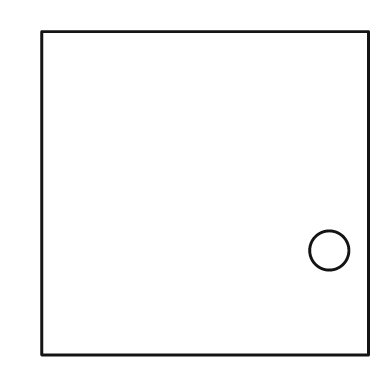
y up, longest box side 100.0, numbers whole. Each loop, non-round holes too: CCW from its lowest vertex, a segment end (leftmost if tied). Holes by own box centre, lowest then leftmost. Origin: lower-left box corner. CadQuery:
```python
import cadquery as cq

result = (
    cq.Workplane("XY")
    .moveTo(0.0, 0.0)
    .lineTo(100.0, 0.0)
    .lineTo(100.0, 99.0)
    .lineTo(0.0, 99.0)
    .close()
    .moveTo(88.0, 32.0)
    .circle(6.0)
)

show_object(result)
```